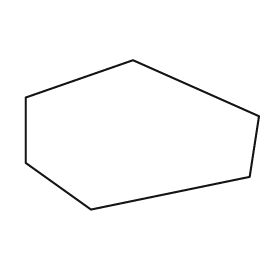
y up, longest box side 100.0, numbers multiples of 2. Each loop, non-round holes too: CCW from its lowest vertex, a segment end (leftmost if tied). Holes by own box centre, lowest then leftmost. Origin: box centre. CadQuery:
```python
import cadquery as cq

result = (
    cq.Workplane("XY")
    .moveTo(-22.0, -32.0)
    .lineTo(46.0, -18.0)
    .lineTo(50.0, 8.0)
    .lineTo(-4.0, 32.0)
    .lineTo(-50.0, 16.0)
    .lineTo(-50.0, -12.0)
    .close()
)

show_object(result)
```